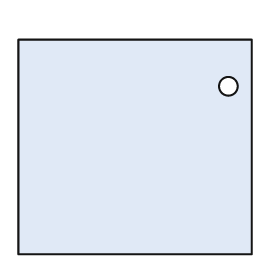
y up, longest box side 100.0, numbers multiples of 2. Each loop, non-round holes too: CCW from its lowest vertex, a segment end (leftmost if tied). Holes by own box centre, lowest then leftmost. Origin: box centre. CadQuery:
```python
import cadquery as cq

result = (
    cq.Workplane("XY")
    .moveTo(-50.0, -46.0)
    .lineTo(50.0, -46.0)
    .lineTo(50.0, 46.0)
    .lineTo(-50.0, 46.0)
    .close()
    .moveTo(40.0, 26.0)
    .circle(4.0)
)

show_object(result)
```